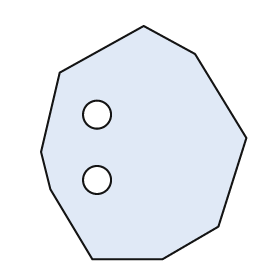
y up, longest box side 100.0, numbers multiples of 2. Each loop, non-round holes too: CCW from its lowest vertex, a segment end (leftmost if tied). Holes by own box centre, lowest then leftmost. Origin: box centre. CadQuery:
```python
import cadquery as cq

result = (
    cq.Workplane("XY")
    .moveTo(-22.0, -50.0)
    .lineTo(8.0, -50.0)
    .lineTo(32.0, -36.0)
    .lineTo(44.0, 2.0)
    .lineTo(22.0, 38.0)
    .lineTo(0.0, 50.0)
    .lineTo(-36.0, 30.0)
    .lineTo(-44.0, -4.0)
    .lineTo(-40.0, -20.0)
    .close()
    .moveTo(-20.0, -16.0)
    .circle(6.0)
    .moveTo(-20.0, 12.0)
    .circle(6.0)
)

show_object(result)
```